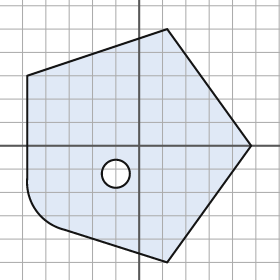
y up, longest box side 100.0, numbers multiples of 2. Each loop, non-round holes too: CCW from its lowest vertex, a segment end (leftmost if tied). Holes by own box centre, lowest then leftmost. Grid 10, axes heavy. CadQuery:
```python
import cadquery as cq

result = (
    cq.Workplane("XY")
    .moveTo(12.0, -50.0)
    .lineTo(48.0, 0.0)
    .lineTo(12.0, 50.0)
    .lineTo(-48.0, 30.0)
    .lineTo(-48.0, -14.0)
    .threePointArc((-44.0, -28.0), (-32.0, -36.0))
    .close()
    .moveTo(-10.0, -12.0)
    .circle(6.0)
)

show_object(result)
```